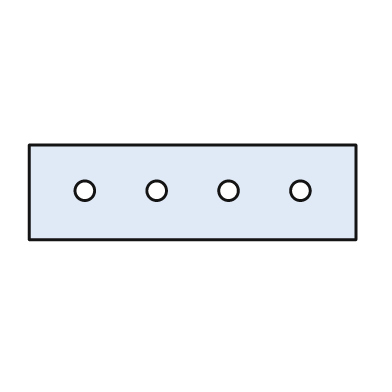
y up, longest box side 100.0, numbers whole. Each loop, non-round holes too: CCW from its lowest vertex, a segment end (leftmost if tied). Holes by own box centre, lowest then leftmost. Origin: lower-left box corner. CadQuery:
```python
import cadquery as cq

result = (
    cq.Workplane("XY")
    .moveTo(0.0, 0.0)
    .lineTo(100.0, 0.0)
    .lineTo(100.0, 29.0)
    .lineTo(0.0, 29.0)
    .close()
    .moveTo(17.0, 15.0)
    .circle(3.0)
    .moveTo(39.0, 15.0)
    .circle(3.0)
    .moveTo(61.0, 15.0)
    .circle(3.0)
    .moveTo(83.0, 15.0)
    .circle(3.0)
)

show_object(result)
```